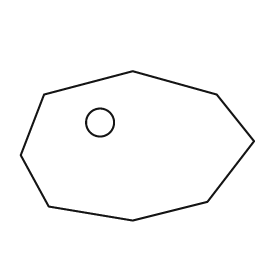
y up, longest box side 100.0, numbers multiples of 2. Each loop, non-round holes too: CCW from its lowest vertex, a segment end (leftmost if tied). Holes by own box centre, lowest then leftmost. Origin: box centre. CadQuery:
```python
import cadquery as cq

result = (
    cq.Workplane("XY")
    .moveTo(-2.0, -32.0)
    .lineTo(30.0, -24.0)
    .lineTo(50.0, 2.0)
    .lineTo(34.0, 22.0)
    .lineTo(-2.0, 32.0)
    .lineTo(-40.0, 22.0)
    .lineTo(-50.0, -4.0)
    .lineTo(-38.0, -26.0)
    .close()
    .moveTo(-16.0, 10.0)
    .circle(6.0)
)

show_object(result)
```